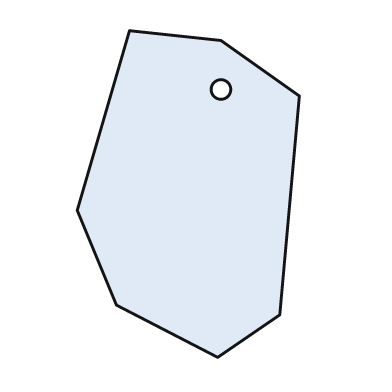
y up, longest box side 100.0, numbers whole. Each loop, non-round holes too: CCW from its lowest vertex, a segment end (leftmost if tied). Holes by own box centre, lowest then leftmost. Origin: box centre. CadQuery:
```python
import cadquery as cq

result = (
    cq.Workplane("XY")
    .moveTo(9.0, -50.0)
    .lineTo(28.0, -37.0)
    .lineTo(34.0, 30.0)
    .lineTo(10.0, 47.0)
    .lineTo(-18.0, 50.0)
    .lineTo(-34.0, -5.0)
    .lineTo(-22.0, -34.0)
    .close()
    .moveTo(10.0, 32.0)
    .circle(3.0)
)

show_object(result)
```